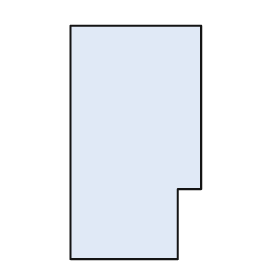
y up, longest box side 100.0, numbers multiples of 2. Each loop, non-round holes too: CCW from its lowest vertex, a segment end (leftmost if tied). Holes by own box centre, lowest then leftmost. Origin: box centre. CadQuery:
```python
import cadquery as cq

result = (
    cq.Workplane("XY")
    .moveTo(-28.0, -50.0)
    .lineTo(18.0, -50.0)
    .lineTo(18.0, -20.0)
    .lineTo(28.0, -20.0)
    .lineTo(28.0, 50.0)
    .lineTo(-28.0, 50.0)
    .close()
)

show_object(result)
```